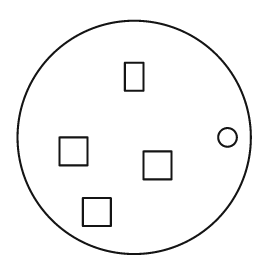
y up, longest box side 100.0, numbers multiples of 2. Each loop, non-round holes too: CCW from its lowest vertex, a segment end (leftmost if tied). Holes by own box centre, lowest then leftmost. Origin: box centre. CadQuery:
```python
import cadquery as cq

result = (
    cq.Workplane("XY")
    .moveTo(0.0, 0.0)
    .circle(50.0)
    .moveTo(-22.0, -38.0)
    .lineTo(-10.0, -38.0)
    .lineTo(-10.0, -26.0)
    .lineTo(-22.0, -26.0)
    .close()
    .moveTo(4.0, -18.0)
    .lineTo(16.0, -18.0)
    .lineTo(16.0, -6.0)
    .lineTo(4.0, -6.0)
    .close()
    .moveTo(-32.0, -12.0)
    .lineTo(-20.0, -12.0)
    .lineTo(-20.0, 0.0)
    .lineTo(-32.0, 0.0)
    .close()
    .moveTo(40.0, 0.0)
    .circle(4.0)
    .moveTo(-4.0, 20.0)
    .lineTo(4.0, 20.0)
    .lineTo(4.0, 32.0)
    .lineTo(-4.0, 32.0)
    .close()
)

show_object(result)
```